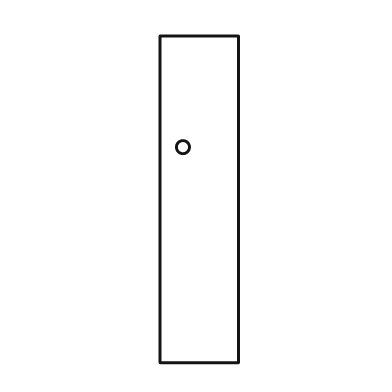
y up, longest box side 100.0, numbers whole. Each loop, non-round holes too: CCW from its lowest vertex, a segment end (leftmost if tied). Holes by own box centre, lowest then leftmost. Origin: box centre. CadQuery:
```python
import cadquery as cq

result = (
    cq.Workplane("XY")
    .moveTo(-12.0, -50.0)
    .lineTo(12.0, -50.0)
    .lineTo(12.0, 50.0)
    .lineTo(-12.0, 50.0)
    .close()
    .moveTo(-5.0, 16.0)
    .circle(2.0)
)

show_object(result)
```